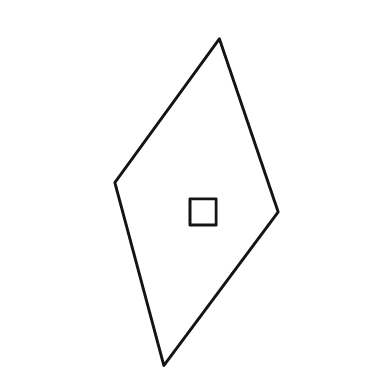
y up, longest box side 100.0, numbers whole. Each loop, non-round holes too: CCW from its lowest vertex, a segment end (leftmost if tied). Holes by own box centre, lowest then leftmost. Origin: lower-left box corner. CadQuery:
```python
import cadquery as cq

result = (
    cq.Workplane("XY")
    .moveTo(15.0, 0.0)
    .lineTo(50.0, 47.0)
    .lineTo(32.0, 100.0)
    .lineTo(0.0, 56.0)
    .close()
    .moveTo(23.0, 43.0)
    .lineTo(31.0, 43.0)
    .lineTo(31.0, 51.0)
    .lineTo(23.0, 51.0)
    .close()
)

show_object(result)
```